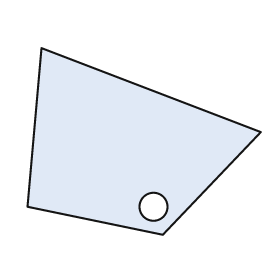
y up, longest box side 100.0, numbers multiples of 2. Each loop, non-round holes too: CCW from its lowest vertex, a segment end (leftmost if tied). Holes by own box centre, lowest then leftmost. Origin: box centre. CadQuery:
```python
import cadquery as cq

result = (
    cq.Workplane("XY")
    .moveTo(8.0, -40.0)
    .lineTo(50.0, 4.0)
    .lineTo(-44.0, 40.0)
    .lineTo(-50.0, -28.0)
    .close()
    .moveTo(4.0, -28.0)
    .circle(6.0)
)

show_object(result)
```